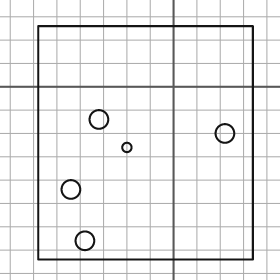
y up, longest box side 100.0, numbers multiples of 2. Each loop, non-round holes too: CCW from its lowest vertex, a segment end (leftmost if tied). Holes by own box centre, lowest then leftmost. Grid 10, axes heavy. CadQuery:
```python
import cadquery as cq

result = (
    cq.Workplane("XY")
    .moveTo(-58.0, -74.0)
    .lineTo(34.0, -74.0)
    .lineTo(34.0, 26.0)
    .lineTo(-58.0, 26.0)
    .close()
    .moveTo(-38.0, -66.0)
    .circle(4.0)
    .moveTo(-44.0, -44.0)
    .circle(4.0)
    .moveTo(-20.0, -26.0)
    .circle(2.0)
    .moveTo(22.0, -20.0)
    .circle(4.0)
    .moveTo(-32.0, -14.0)
    .circle(4.0)
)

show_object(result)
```